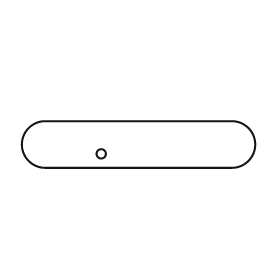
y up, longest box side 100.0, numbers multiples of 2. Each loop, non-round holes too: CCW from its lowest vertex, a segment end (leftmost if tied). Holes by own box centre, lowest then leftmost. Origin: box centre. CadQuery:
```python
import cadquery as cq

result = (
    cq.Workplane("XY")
    .moveTo(-40.0, -10.0)
    .lineTo(40.0, -10.0)
    .threePointArc((50.0, 0.0), (40.0, 10.0))
    .lineTo(-40.0, 10.0)
    .threePointArc((-50.0, 0.0), (-40.0, -10.0))
    .close()
    .moveTo(-16.0, -4.0)
    .circle(2.0)
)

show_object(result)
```